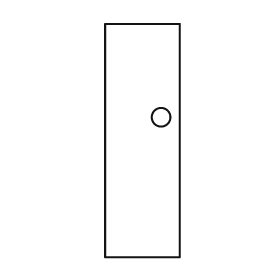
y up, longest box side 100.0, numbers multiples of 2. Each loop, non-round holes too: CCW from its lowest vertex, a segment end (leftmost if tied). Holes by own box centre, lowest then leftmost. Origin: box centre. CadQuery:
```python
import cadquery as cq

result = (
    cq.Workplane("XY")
    .moveTo(-16.0, -50.0)
    .lineTo(16.0, -50.0)
    .lineTo(16.0, 50.0)
    .lineTo(-16.0, 50.0)
    .close()
    .moveTo(8.0, 10.0)
    .circle(4.0)
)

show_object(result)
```